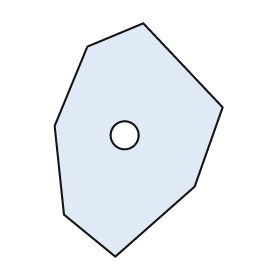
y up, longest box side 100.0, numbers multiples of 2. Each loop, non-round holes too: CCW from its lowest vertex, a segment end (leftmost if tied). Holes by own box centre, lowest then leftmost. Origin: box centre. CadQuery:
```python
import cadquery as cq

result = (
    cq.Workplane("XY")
    .moveTo(-10.0, -50.0)
    .lineTo(24.0, -20.0)
    .lineTo(36.0, 14.0)
    .lineTo(2.0, 50.0)
    .lineTo(-22.0, 40.0)
    .lineTo(-36.0, 6.0)
    .lineTo(-32.0, -32.0)
    .close()
    .moveTo(-6.0, 2.0)
    .circle(6.0)
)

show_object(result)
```